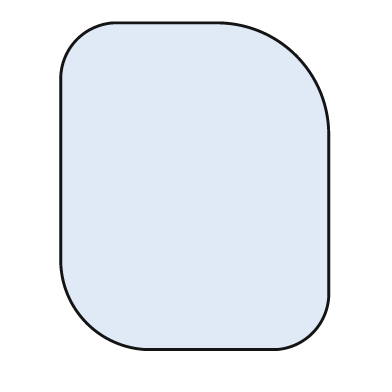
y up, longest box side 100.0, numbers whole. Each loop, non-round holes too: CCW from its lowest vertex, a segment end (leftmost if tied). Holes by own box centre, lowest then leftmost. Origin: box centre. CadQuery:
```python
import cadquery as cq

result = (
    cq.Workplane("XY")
    .moveTo(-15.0, -50.0)
    .lineTo(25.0, -50.0)
    .threePointArc((36.0, -45.0), (41.0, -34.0))
    .lineTo(41.0, 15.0)
    .threePointArc((31.0, 40.0), (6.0, 50.0))
    .lineTo(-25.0, 50.0)
    .threePointArc((-36.0, 45.0), (-41.0, 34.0))
    .lineTo(-41.0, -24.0)
    .threePointArc((-33.0, -42.0), (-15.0, -50.0))
    .close()
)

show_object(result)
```